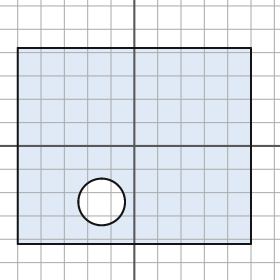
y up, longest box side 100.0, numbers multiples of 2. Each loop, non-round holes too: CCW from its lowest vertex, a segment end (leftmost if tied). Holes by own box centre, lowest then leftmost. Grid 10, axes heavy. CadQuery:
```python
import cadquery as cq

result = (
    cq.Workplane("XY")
    .moveTo(-50.0, -42.0)
    .lineTo(50.0, -42.0)
    .lineTo(50.0, 42.0)
    .lineTo(-50.0, 42.0)
    .close()
    .moveTo(-14.0, -24.0)
    .circle(10.0)
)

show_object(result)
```